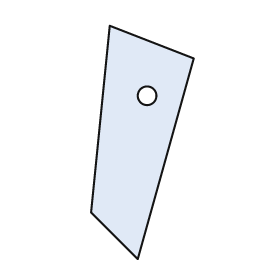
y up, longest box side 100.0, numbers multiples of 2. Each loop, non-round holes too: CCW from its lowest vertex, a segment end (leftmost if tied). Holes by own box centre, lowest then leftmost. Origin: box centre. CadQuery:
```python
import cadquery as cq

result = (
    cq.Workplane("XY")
    .moveTo(-2.0, -50.0)
    .lineTo(22.0, 36.0)
    .lineTo(-14.0, 50.0)
    .lineTo(-22.0, -30.0)
    .close()
    .moveTo(2.0, 20.0)
    .circle(4.0)
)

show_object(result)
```